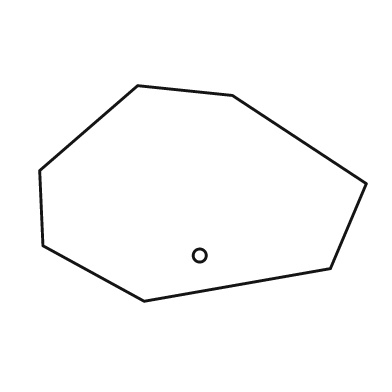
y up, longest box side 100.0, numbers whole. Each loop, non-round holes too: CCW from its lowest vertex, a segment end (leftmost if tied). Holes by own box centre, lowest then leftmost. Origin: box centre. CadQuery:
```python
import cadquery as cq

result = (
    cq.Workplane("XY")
    .moveTo(-18.0, -33.0)
    .lineTo(39.0, -23.0)
    .lineTo(50.0, 3.0)
    .lineTo(9.0, 30.0)
    .lineTo(-20.0, 33.0)
    .lineTo(-50.0, 7.0)
    .lineTo(-49.0, -16.0)
    .close()
    .moveTo(-1.0, -19.0)
    .circle(2.0)
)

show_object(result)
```